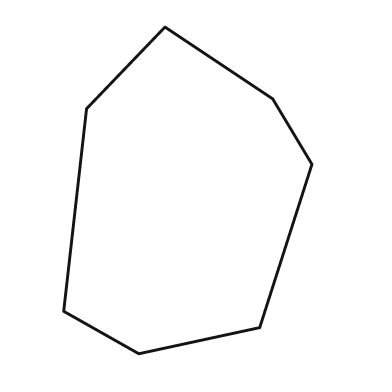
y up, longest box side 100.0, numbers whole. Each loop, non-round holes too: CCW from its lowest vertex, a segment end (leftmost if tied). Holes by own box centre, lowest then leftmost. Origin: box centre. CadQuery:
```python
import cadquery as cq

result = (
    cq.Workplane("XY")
    .moveTo(-15.0, -50.0)
    .lineTo(22.0, -42.0)
    .lineTo(38.0, 8.0)
    .lineTo(26.0, 28.0)
    .lineTo(-7.0, 50.0)
    .lineTo(-31.0, 25.0)
    .lineTo(-38.0, -37.0)
    .close()
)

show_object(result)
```